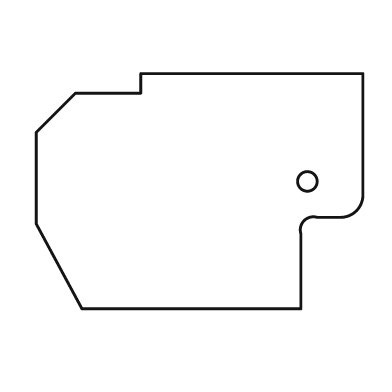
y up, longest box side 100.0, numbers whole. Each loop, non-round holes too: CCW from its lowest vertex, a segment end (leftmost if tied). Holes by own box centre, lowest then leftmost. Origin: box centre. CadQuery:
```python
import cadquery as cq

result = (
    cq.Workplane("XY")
    .moveTo(-36.0, -36.0)
    .lineTo(31.0, -36.0)
    .lineTo(31.0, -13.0)
    .threePointArc((32.0, -9.0), (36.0, -8.0))
    .lineTo(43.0, -8.0)
    .threePointArc((48.0, -6.0), (50.0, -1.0))
    .lineTo(50.0, 36.0)
    .lineTo(-18.0, 36.0)
    .lineTo(-18.0, 30.0)
    .lineTo(-38.0, 30.0)
    .lineTo(-50.0, 18.0)
    .lineTo(-50.0, -10.0)
    .close()
    .moveTo(33.0, 3.0)
    .circle(3.0)
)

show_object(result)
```